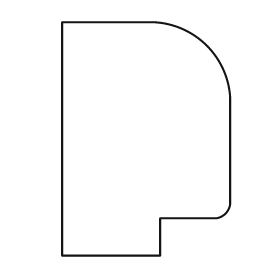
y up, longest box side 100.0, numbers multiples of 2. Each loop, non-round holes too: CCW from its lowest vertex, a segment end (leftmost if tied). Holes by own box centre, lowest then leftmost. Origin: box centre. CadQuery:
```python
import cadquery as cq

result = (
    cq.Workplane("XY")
    .moveTo(-36.0, -50.0)
    .lineTo(6.0, -50.0)
    .lineTo(6.0, -34.0)
    .lineTo(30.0, -34.0)
    .threePointArc((34.0, -32.0), (36.0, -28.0))
    .lineTo(36.0, 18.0)
    .threePointArc((26.0, 40.0), (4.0, 50.0))
    .lineTo(-36.0, 50.0)
    .close()
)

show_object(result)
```